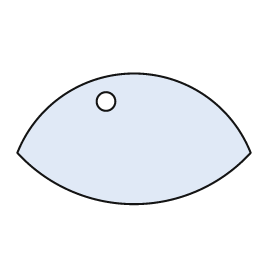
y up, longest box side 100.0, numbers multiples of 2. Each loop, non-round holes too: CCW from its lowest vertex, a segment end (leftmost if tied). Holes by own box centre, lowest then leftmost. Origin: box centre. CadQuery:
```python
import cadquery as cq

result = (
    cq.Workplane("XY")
    .moveTo(-50.0, -6.0)
    .threePointArc((0.0, -28.0), (50.0, -6.0))
    .threePointArc((0.0, 28.0), (-50.0, -6.0))
    .close()
    .moveTo(-12.0, 16.0)
    .circle(4.0)
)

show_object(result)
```